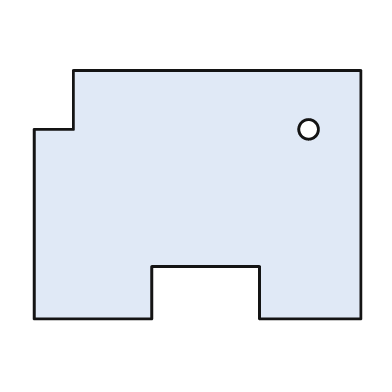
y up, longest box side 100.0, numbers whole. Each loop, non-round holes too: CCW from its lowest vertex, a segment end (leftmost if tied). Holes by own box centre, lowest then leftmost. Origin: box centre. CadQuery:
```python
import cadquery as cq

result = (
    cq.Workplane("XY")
    .moveTo(-50.0, -38.0)
    .lineTo(-14.0, -38.0)
    .lineTo(-14.0, -22.0)
    .lineTo(19.0, -22.0)
    .lineTo(19.0, -38.0)
    .lineTo(50.0, -38.0)
    .lineTo(50.0, 38.0)
    .lineTo(-38.0, 38.0)
    .lineTo(-38.0, 20.0)
    .lineTo(-50.0, 20.0)
    .close()
    .moveTo(34.0, 20.0)
    .circle(3.0)
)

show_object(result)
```